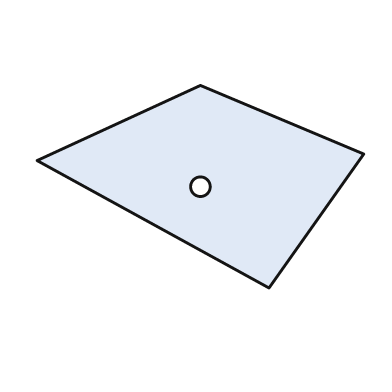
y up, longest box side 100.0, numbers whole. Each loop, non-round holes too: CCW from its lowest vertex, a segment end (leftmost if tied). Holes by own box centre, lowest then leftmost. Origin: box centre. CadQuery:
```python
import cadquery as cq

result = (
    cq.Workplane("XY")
    .moveTo(21.0, -31.0)
    .lineTo(50.0, 10.0)
    .lineTo(0.0, 31.0)
    .lineTo(-50.0, 8.0)
    .close()
    .moveTo(0.0, 0.0)
    .circle(3.0)
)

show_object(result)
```